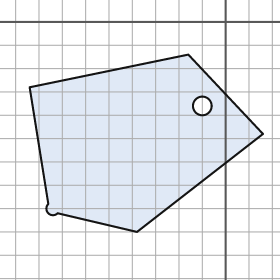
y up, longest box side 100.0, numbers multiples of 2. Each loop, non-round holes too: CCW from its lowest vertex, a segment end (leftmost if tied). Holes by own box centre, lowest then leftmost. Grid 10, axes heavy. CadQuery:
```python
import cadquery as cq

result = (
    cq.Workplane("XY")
    .moveTo(-38.0, -90.0)
    .lineTo(16.0, -48.0)
    .lineTo(-16.0, -14.0)
    .lineTo(-84.0, -28.0)
    .lineTo(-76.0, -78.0)
    .threePointArc((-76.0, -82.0), (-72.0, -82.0))
    .close()
    .moveTo(-10.0, -36.0)
    .circle(4.0)
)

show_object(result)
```